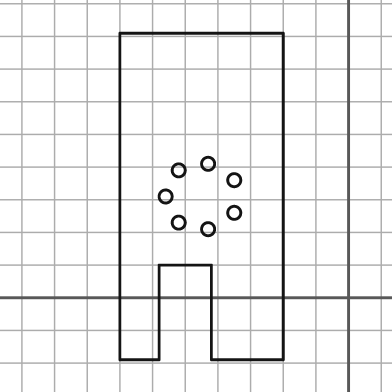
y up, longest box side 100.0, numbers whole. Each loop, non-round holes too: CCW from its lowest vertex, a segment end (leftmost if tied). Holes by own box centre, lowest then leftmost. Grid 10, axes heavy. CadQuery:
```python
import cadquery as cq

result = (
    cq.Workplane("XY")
    .moveTo(-70.0, -19.0)
    .lineTo(-58.0, -19.0)
    .lineTo(-58.0, 10.0)
    .lineTo(-42.0, 10.0)
    .lineTo(-42.0, -19.0)
    .lineTo(-20.0, -19.0)
    .lineTo(-20.0, 81.0)
    .lineTo(-70.0, 81.0)
    .close()
    .moveTo(-43.0, 21.0)
    .circle(2.0)
    .moveTo(-52.0, 23.0)
    .circle(2.0)
    .moveTo(-35.0, 26.0)
    .circle(2.0)
    .moveTo(-56.0, 31.0)
    .circle(2.0)
    .moveTo(-35.0, 36.0)
    .circle(2.0)
    .moveTo(-52.0, 39.0)
    .circle(2.0)
    .moveTo(-43.0, 41.0)
    .circle(2.0)
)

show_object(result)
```